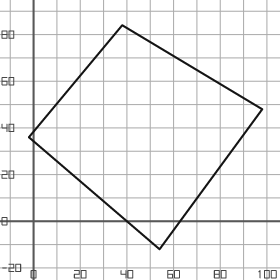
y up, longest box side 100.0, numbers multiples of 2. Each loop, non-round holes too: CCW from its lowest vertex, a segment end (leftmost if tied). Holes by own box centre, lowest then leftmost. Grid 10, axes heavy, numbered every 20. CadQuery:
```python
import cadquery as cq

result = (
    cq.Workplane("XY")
    .moveTo(54.0, -12.0)
    .lineTo(98.0, 48.0)
    .lineTo(38.0, 84.0)
    .lineTo(-2.0, 36.0)
    .close()
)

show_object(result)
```